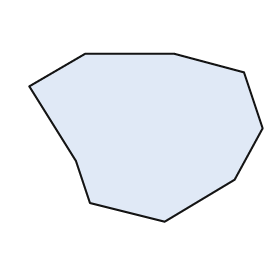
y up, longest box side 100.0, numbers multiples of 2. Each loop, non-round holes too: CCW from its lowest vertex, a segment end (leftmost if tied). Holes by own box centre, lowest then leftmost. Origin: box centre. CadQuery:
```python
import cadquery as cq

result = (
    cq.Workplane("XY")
    .moveTo(8.0, -36.0)
    .lineTo(38.0, -18.0)
    .lineTo(50.0, 4.0)
    .lineTo(42.0, 28.0)
    .lineTo(12.0, 36.0)
    .lineTo(-26.0, 36.0)
    .lineTo(-50.0, 22.0)
    .lineTo(-30.0, -10.0)
    .lineTo(-24.0, -28.0)
    .close()
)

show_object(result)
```